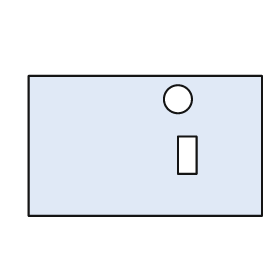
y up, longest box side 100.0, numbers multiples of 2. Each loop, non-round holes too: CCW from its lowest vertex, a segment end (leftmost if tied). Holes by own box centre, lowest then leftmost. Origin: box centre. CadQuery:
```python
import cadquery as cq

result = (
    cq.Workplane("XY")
    .moveTo(-50.0, -30.0)
    .lineTo(50.0, -30.0)
    .lineTo(50.0, 30.0)
    .lineTo(-50.0, 30.0)
    .close()
    .moveTo(14.0, -12.0)
    .lineTo(22.0, -12.0)
    .lineTo(22.0, 4.0)
    .lineTo(14.0, 4.0)
    .close()
    .moveTo(14.0, 20.0)
    .circle(6.0)
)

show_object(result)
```